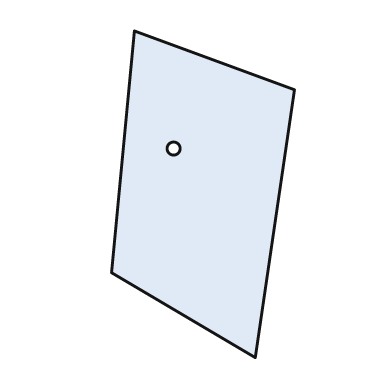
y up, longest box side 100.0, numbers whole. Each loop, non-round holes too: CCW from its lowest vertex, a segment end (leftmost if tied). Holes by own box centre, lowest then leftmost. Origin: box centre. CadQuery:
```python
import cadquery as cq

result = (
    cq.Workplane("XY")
    .moveTo(16.0, -50.0)
    .lineTo(28.0, 32.0)
    .lineTo(-21.0, 50.0)
    .lineTo(-28.0, -24.0)
    .close()
    .moveTo(-9.0, 14.0)
    .circle(2.0)
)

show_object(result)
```